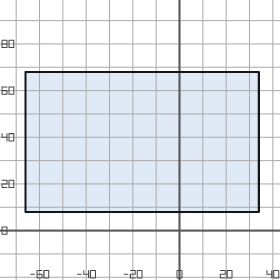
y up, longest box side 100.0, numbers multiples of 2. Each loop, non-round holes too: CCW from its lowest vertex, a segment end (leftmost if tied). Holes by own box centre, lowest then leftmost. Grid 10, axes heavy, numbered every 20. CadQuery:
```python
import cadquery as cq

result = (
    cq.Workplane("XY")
    .moveTo(-66.0, 8.0)
    .lineTo(34.0, 8.0)
    .lineTo(34.0, 68.0)
    .lineTo(-66.0, 68.0)
    .close()
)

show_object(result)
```